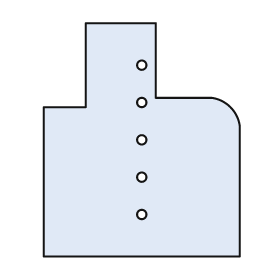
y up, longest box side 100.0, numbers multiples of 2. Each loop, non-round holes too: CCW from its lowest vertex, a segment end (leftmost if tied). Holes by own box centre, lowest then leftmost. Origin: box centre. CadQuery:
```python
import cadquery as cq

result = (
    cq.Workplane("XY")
    .moveTo(-42.0, -50.0)
    .lineTo(42.0, -50.0)
    .lineTo(42.0, 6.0)
    .threePointArc((38.0, 14.0), (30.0, 18.0))
    .lineTo(6.0, 18.0)
    .lineTo(6.0, 50.0)
    .lineTo(-24.0, 50.0)
    .lineTo(-24.0, 14.0)
    .lineTo(-42.0, 14.0)
    .close()
    .moveTo(0.0, -32.0)
    .circle(2.0)
    .moveTo(0.0, -16.0)
    .circle(2.0)
    .moveTo(0.0, 0.0)
    .circle(2.0)
    .moveTo(0.0, 16.0)
    .circle(2.0)
    .moveTo(0.0, 32.0)
    .circle(2.0)
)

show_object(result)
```